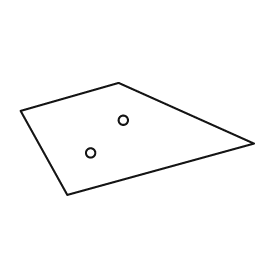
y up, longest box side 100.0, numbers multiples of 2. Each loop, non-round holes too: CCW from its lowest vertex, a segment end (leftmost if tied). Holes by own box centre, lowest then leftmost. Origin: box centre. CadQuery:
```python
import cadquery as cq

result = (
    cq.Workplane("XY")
    .moveTo(-30.0, -24.0)
    .lineTo(50.0, -2.0)
    .lineTo(-8.0, 24.0)
    .lineTo(-50.0, 12.0)
    .close()
    .moveTo(-20.0, -6.0)
    .circle(2.0)
    .moveTo(-6.0, 8.0)
    .circle(2.0)
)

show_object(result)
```